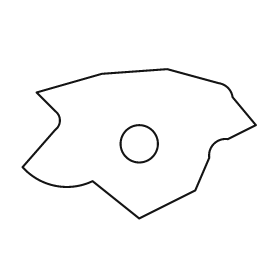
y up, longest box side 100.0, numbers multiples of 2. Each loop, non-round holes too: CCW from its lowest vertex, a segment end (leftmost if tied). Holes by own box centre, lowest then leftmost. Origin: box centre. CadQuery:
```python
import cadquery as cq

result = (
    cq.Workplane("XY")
    .moveTo(0.0, -32.0)
    .lineTo(24.0, -20.0)
    .lineTo(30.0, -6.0)
    .threePointArc((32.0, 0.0), (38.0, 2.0))
    .lineTo(50.0, 8.0)
    .lineTo(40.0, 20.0)
    .threePointArc((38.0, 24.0), (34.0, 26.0))
    .lineTo(12.0, 32.0)
    .lineTo(-16.0, 30.0)
    .lineTo(-44.0, 22.0)
    .lineTo(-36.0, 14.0)
    .threePointArc((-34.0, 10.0), (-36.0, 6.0))
    .lineTo(-50.0, -10.0)
    .threePointArc((-36.0, -18.0), (-20.0, -16.0))
    .close()
    .moveTo(0.0, 0.0)
    .circle(8.0)
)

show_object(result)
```